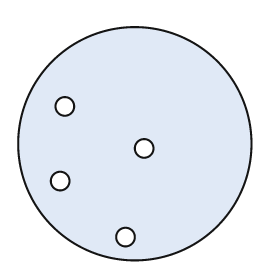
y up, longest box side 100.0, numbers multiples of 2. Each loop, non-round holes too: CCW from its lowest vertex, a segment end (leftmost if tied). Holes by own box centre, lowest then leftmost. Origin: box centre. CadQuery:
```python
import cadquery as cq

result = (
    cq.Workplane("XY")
    .moveTo(0.0, 0.0)
    .circle(50.0)
    .moveTo(-4.0, -40.0)
    .circle(4.0)
    .moveTo(-32.0, -16.0)
    .circle(4.0)
    .moveTo(4.0, -2.0)
    .circle(4.0)
    .moveTo(-30.0, 16.0)
    .circle(4.0)
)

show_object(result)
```